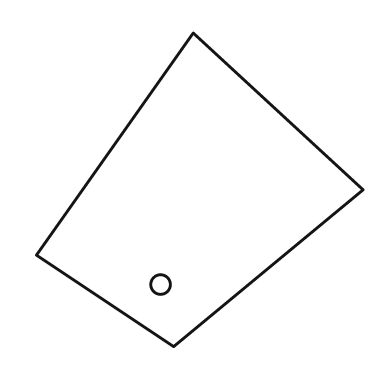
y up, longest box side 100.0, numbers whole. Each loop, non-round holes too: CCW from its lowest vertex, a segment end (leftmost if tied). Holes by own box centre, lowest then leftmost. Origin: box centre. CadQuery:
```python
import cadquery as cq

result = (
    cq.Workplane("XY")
    .moveTo(-8.0, -48.0)
    .lineTo(50.0, 0.0)
    .lineTo(-2.0, 48.0)
    .lineTo(-50.0, -20.0)
    .close()
    .moveTo(-12.0, -29.0)
    .circle(3.0)
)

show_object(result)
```